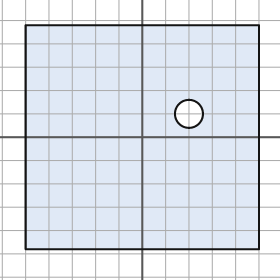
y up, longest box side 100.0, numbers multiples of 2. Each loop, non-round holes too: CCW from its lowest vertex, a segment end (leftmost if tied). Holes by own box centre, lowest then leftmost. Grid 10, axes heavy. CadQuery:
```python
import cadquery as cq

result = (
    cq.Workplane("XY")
    .moveTo(-50.0, -48.0)
    .lineTo(50.0, -48.0)
    .lineTo(50.0, 48.0)
    .lineTo(-50.0, 48.0)
    .close()
    .moveTo(20.0, 10.0)
    .circle(6.0)
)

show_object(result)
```